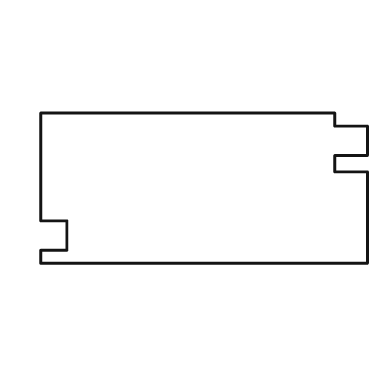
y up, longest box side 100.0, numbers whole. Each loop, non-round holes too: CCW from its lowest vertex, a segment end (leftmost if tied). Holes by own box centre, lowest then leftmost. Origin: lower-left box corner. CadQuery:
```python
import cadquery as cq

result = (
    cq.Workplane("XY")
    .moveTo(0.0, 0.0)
    .lineTo(100.0, 0.0)
    .lineTo(100.0, 28.0)
    .lineTo(90.0, 28.0)
    .lineTo(90.0, 33.0)
    .lineTo(100.0, 33.0)
    .lineTo(100.0, 42.0)
    .lineTo(90.0, 42.0)
    .lineTo(90.0, 46.0)
    .lineTo(0.0, 46.0)
    .lineTo(0.0, 13.0)
    .lineTo(8.0, 13.0)
    .lineTo(8.0, 4.0)
    .lineTo(0.0, 4.0)
    .close()
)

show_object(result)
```